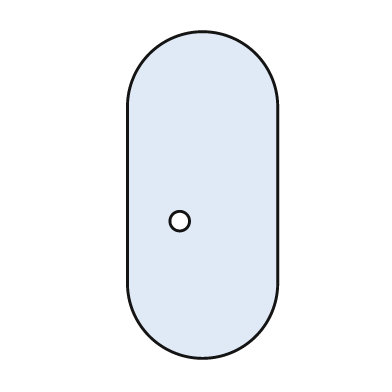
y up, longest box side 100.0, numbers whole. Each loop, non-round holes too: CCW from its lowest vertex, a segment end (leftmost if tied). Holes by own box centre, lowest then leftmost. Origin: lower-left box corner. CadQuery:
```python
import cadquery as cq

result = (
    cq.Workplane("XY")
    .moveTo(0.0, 23.0)
    .threePointArc((23.0, 0.0), (46.0, 23.0))
    .lineTo(46.0, 77.0)
    .threePointArc((23.0, 100.0), (0.0, 77.0))
    .close()
    .moveTo(16.0, 42.0)
    .circle(3.0)
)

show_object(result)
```